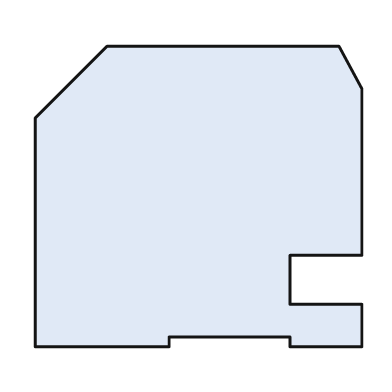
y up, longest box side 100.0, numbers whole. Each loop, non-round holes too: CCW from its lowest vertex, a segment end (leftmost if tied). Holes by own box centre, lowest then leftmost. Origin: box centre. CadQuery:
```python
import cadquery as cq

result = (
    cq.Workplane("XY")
    .moveTo(-50.0, -46.0)
    .lineTo(-9.0, -46.0)
    .lineTo(-9.0, -43.0)
    .lineTo(28.0, -43.0)
    .lineTo(28.0, -46.0)
    .lineTo(50.0, -46.0)
    .lineTo(50.0, -33.0)
    .lineTo(28.0, -33.0)
    .lineTo(28.0, -18.0)
    .lineTo(50.0, -18.0)
    .lineTo(50.0, 33.0)
    .lineTo(43.0, 46.0)
    .lineTo(-28.0, 46.0)
    .lineTo(-50.0, 24.0)
    .close()
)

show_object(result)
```